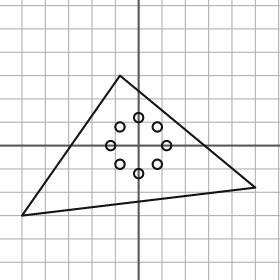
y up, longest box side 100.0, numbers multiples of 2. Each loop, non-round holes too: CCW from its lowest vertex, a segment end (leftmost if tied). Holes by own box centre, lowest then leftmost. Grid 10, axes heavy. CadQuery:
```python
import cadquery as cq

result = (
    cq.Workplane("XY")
    .moveTo(-50.0, -30.0)
    .lineTo(50.0, -18.0)
    .lineTo(-8.0, 30.0)
    .close()
    .moveTo(0.0, -12.0)
    .circle(2.0)
    .moveTo(-8.0, -8.0)
    .circle(2.0)
    .moveTo(8.0, -8.0)
    .circle(2.0)
    .moveTo(-12.0, 0.0)
    .circle(2.0)
    .moveTo(12.0, 0.0)
    .circle(2.0)
    .moveTo(-8.0, 8.0)
    .circle(2.0)
    .moveTo(8.0, 8.0)
    .circle(2.0)
    .moveTo(0.0, 12.0)
    .circle(2.0)
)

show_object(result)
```